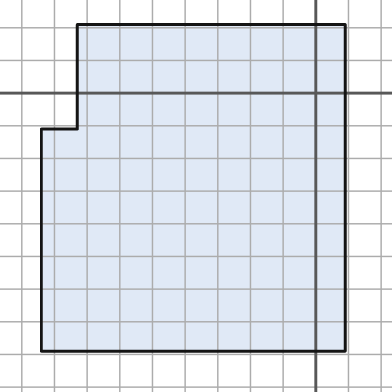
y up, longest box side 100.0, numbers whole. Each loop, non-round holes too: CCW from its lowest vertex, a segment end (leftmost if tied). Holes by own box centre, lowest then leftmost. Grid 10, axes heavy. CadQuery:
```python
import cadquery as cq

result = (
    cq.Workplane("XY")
    .moveTo(-84.0, -79.0)
    .lineTo(9.0, -79.0)
    .lineTo(9.0, 21.0)
    .lineTo(-73.0, 21.0)
    .lineTo(-73.0, -11.0)
    .lineTo(-84.0, -11.0)
    .close()
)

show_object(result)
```